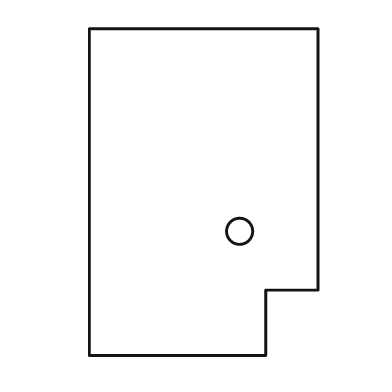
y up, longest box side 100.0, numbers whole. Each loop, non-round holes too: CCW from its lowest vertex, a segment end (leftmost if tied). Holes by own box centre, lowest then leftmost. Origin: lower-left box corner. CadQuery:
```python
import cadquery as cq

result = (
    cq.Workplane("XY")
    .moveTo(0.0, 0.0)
    .lineTo(54.0, 0.0)
    .lineTo(54.0, 20.0)
    .lineTo(70.0, 20.0)
    .lineTo(70.0, 100.0)
    .lineTo(0.0, 100.0)
    .close()
    .moveTo(46.0, 38.0)
    .circle(4.0)
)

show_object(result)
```